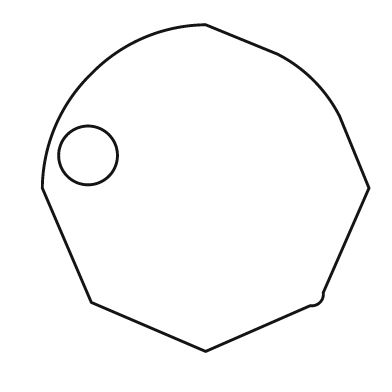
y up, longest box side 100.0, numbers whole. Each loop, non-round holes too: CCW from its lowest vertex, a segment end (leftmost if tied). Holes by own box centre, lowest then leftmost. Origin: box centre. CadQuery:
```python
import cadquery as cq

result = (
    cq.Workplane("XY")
    .moveTo(0.0, -50.0)
    .lineTo(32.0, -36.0)
    .threePointArc((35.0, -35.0), (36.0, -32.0))
    .lineTo(50.0, 0.0)
    .lineTo(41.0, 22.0)
    .threePointArc((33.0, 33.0), (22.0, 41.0))
    .lineTo(0.0, 50.0)
    .threePointArc((-19.0, 46.0), (-35.0, 35.0))
    .threePointArc((-46.0, 19.0), (-50.0, 0.0))
    .lineTo(-35.0, -35.0)
    .close()
    .moveTo(-36.0, 10.0)
    .circle(9.0)
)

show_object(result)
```